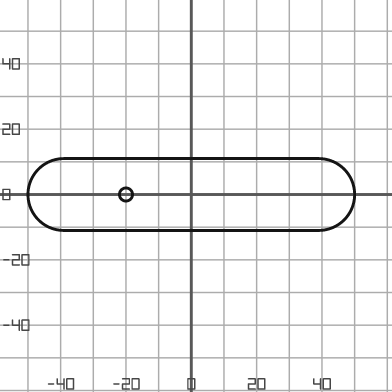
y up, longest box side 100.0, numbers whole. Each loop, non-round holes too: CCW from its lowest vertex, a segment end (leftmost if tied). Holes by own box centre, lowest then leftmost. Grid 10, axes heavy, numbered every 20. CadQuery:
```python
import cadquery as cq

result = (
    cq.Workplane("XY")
    .moveTo(-39.0, -11.0)
    .lineTo(39.0, -11.0)
    .threePointArc((50.0, 0.0), (39.0, 11.0))
    .lineTo(-39.0, 11.0)
    .threePointArc((-50.0, 0.0), (-39.0, -11.0))
    .close()
    .moveTo(-20.0, 0.0)
    .circle(2.0)
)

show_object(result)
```